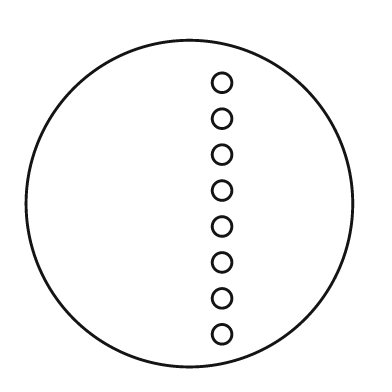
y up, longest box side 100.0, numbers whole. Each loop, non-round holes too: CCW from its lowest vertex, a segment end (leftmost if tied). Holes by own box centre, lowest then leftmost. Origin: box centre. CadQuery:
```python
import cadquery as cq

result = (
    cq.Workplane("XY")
    .moveTo(0.0, 0.0)
    .circle(50.0)
    .moveTo(10.0, -40.0)
    .circle(3.0)
    .moveTo(10.0, -29.0)
    .circle(3.0)
    .moveTo(10.0, -18.0)
    .circle(3.0)
    .moveTo(10.0, -7.0)
    .circle(3.0)
    .moveTo(10.0, 4.0)
    .circle(3.0)
    .moveTo(10.0, 15.0)
    .circle(3.0)
    .moveTo(10.0, 26.0)
    .circle(3.0)
    .moveTo(10.0, 37.0)
    .circle(3.0)
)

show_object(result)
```